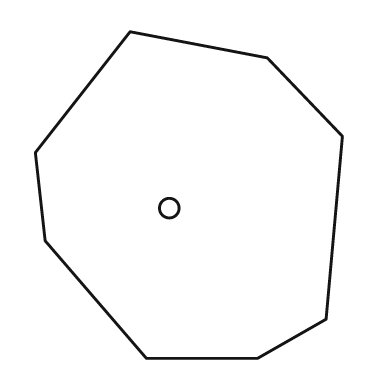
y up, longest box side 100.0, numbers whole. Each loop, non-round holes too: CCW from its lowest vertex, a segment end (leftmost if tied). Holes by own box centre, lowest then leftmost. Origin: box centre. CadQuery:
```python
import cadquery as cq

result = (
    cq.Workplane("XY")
    .moveTo(-13.0, -50.0)
    .lineTo(21.0, -50.0)
    .lineTo(42.0, -38.0)
    .lineTo(47.0, 18.0)
    .lineTo(24.0, 42.0)
    .lineTo(-18.0, 50.0)
    .lineTo(-47.0, 13.0)
    .lineTo(-44.0, -14.0)
    .close()
    .moveTo(-6.0, -4.0)
    .circle(3.0)
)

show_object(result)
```